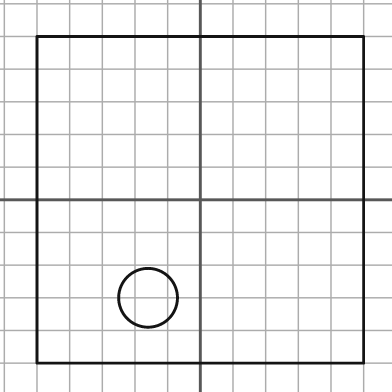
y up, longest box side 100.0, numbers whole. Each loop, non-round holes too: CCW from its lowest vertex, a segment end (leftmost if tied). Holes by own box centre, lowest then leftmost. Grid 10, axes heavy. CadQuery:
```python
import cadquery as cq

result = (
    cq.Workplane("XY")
    .moveTo(-50.0, -50.0)
    .lineTo(50.0, -50.0)
    .lineTo(50.0, 50.0)
    .lineTo(-50.0, 50.0)
    .close()
    .moveTo(-16.0, -30.0)
    .circle(9.0)
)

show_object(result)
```